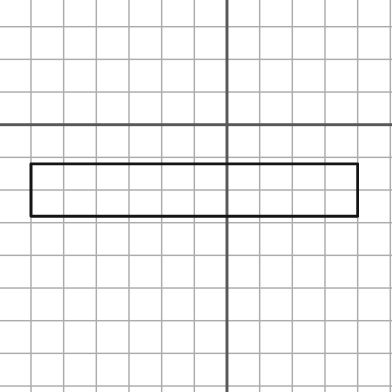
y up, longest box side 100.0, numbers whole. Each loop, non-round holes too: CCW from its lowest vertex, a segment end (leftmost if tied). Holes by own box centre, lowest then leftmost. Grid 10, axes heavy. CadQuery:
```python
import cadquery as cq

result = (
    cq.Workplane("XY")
    .moveTo(-60.0, -28.0)
    .lineTo(40.0, -28.0)
    .lineTo(40.0, -12.0)
    .lineTo(-60.0, -12.0)
    .close()
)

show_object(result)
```